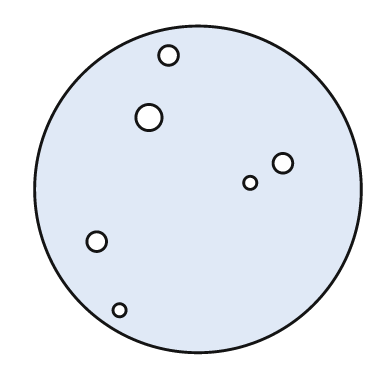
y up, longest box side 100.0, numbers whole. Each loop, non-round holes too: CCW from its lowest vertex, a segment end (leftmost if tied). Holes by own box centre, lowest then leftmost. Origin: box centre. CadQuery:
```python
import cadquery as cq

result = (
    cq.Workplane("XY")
    .moveTo(0.0, 0.0)
    .circle(50.0)
    .moveTo(-24.0, -37.0)
    .circle(2.0)
    .moveTo(-31.0, -16.0)
    .circle(3.0)
    .moveTo(16.0, 2.0)
    .circle(2.0)
    .moveTo(26.0, 8.0)
    .circle(3.0)
    .moveTo(-15.0, 22.0)
    .circle(4.0)
    .moveTo(-9.0, 41.0)
    .circle(3.0)
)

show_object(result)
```